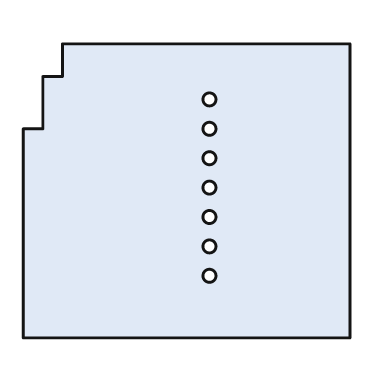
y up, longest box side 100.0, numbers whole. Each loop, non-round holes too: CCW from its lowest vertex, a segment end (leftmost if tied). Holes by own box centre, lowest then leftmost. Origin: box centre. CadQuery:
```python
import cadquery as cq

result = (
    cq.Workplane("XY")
    .moveTo(-50.0, -45.0)
    .lineTo(50.0, -45.0)
    .lineTo(50.0, 45.0)
    .lineTo(-38.0, 45.0)
    .lineTo(-38.0, 35.0)
    .lineTo(-44.0, 35.0)
    .lineTo(-44.0, 19.0)
    .lineTo(-50.0, 19.0)
    .close()
    .moveTo(7.0, -26.0)
    .circle(2.0)
    .moveTo(7.0, -17.0)
    .circle(2.0)
    .moveTo(7.0, -8.0)
    .circle(2.0)
    .moveTo(7.0, 1.0)
    .circle(2.0)
    .moveTo(7.0, 10.0)
    .circle(2.0)
    .moveTo(7.0, 19.0)
    .circle(2.0)
    .moveTo(7.0, 28.0)
    .circle(2.0)
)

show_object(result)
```